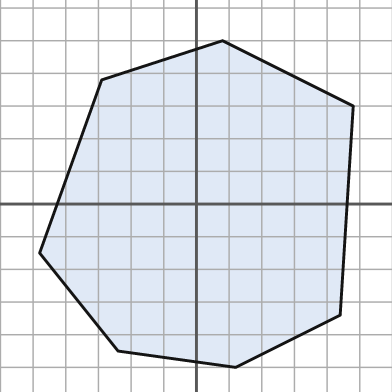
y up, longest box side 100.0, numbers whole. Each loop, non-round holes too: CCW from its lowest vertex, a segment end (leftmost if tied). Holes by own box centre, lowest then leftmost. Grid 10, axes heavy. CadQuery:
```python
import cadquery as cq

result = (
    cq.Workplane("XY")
    .moveTo(12.0, -50.0)
    .lineTo(44.0, -34.0)
    .lineTo(48.0, 30.0)
    .lineTo(8.0, 50.0)
    .lineTo(-29.0, 38.0)
    .lineTo(-48.0, -15.0)
    .lineTo(-24.0, -45.0)
    .close()
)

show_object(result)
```